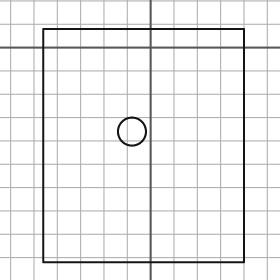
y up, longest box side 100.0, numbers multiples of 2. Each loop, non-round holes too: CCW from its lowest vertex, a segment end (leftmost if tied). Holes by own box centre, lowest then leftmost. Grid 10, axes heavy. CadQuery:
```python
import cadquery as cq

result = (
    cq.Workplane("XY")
    .moveTo(-46.0, -92.0)
    .lineTo(40.0, -92.0)
    .lineTo(40.0, 8.0)
    .lineTo(-46.0, 8.0)
    .close()
    .moveTo(-8.0, -36.0)
    .circle(6.0)
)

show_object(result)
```